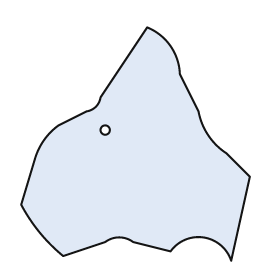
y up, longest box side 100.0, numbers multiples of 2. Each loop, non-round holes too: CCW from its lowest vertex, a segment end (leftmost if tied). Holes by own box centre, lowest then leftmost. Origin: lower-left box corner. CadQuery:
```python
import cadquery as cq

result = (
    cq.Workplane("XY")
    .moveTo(90.0, 0.0)
    .lineTo(98.0, 36.0)
    .lineTo(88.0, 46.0)
    .threePointArc((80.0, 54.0), (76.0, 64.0))
    .lineTo(68.0, 80.0)
    .threePointArc((64.0, 92.0), (54.0, 100.0))
    .lineTo(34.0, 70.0)
    .threePointArc((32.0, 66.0), (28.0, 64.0))
    .lineTo(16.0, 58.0)
    .threePointArc((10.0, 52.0), (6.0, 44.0))
    .lineTo(0.0, 24.0)
    .threePointArc((8.0, 12.0), (18.0, 2.0))
    .lineTo(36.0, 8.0)
    .threePointArc((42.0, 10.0), (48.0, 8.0))
    .lineTo(64.0, 4.0)
    .threePointArc((78.0, 10.0), (90.0, 0.0))
    .close()
    .moveTo(36.0, 56.0)
    .circle(2.0)
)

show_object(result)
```